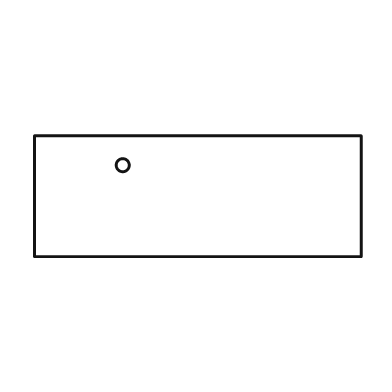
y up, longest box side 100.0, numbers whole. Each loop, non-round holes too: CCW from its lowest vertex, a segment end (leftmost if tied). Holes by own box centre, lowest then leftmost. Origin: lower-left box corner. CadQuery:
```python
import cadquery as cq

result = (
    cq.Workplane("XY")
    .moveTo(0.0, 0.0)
    .lineTo(100.0, 0.0)
    .lineTo(100.0, 37.0)
    .lineTo(0.0, 37.0)
    .close()
    .moveTo(27.0, 28.0)
    .circle(2.0)
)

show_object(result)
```